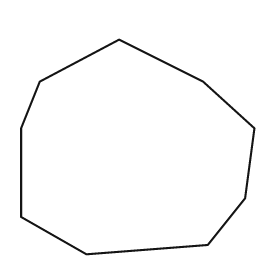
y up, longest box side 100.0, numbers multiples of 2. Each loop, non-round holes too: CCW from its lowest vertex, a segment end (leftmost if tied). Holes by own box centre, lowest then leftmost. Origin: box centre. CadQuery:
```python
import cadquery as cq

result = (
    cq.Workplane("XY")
    .moveTo(-22.0, -46.0)
    .lineTo(30.0, -42.0)
    .lineTo(46.0, -22.0)
    .lineTo(50.0, 8.0)
    .lineTo(28.0, 28.0)
    .lineTo(-8.0, 46.0)
    .lineTo(-42.0, 28.0)
    .lineTo(-50.0, 8.0)
    .lineTo(-50.0, -30.0)
    .close()
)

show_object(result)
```